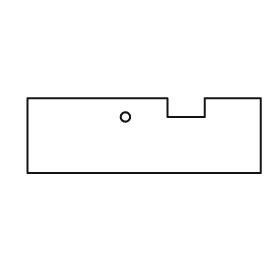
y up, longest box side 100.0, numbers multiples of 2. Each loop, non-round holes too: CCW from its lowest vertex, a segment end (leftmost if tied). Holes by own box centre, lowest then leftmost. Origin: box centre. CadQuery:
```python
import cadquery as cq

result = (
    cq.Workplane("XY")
    .moveTo(-50.0, -16.0)
    .lineTo(50.0, -16.0)
    .lineTo(50.0, 16.0)
    .lineTo(26.0, 16.0)
    .lineTo(26.0, 8.0)
    .lineTo(10.0, 8.0)
    .lineTo(10.0, 16.0)
    .lineTo(-50.0, 16.0)
    .close()
    .moveTo(-8.0, 8.0)
    .circle(2.0)
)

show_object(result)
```